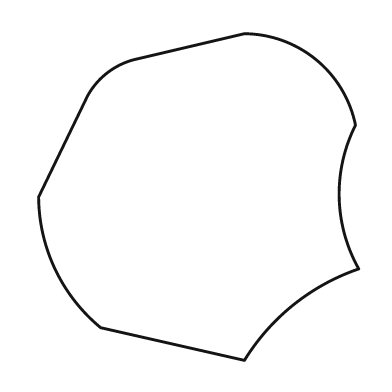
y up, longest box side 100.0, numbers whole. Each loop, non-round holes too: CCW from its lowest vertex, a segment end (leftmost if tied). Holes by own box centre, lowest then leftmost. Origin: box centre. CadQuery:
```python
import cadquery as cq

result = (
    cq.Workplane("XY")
    .moveTo(14.0, -50.0)
    .threePointArc((29.0, -33.0), (49.0, -22.0))
    .threePointArc((43.0, 0.0), (48.0, 22.0))
    .threePointArc((36.0, 42.0), (14.0, 50.0))
    .lineTo(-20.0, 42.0)
    .threePointArc((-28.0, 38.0), (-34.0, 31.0))
    .lineTo(-49.0, 0.0)
    .threePointArc((-44.0, -22.0), (-30.0, -40.0))
    .close()
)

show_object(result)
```